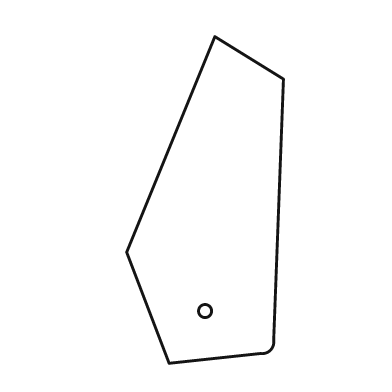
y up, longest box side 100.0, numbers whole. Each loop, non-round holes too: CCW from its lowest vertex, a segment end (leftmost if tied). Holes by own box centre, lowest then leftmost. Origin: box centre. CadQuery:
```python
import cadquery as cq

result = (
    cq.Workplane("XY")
    .moveTo(-11.0, -50.0)
    .lineTo(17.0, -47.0)
    .threePointArc((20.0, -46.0), (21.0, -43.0))
    .lineTo(24.0, 37.0)
    .lineTo(3.0, 50.0)
    .lineTo(-24.0, -16.0)
    .close()
    .moveTo(0.0, -34.0)
    .circle(2.0)
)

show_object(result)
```